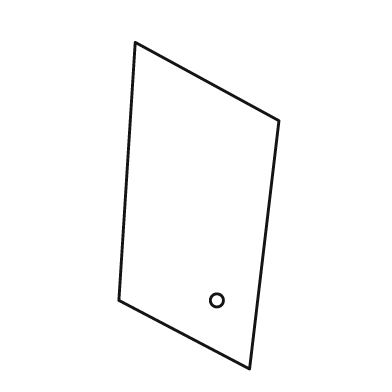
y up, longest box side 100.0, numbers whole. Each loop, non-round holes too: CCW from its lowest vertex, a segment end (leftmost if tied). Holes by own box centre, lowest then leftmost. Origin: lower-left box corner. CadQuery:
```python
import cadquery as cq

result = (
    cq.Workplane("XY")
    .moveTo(40.0, 0.0)
    .lineTo(49.0, 76.0)
    .lineTo(5.0, 100.0)
    .lineTo(0.0, 21.0)
    .close()
    .moveTo(30.0, 21.0)
    .circle(2.0)
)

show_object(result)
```